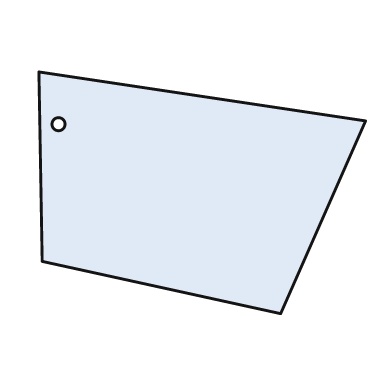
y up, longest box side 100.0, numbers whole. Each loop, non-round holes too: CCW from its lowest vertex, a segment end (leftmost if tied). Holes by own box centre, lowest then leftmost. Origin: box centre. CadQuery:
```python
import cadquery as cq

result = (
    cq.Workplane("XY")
    .moveTo(24.0, -37.0)
    .lineTo(50.0, 22.0)
    .lineTo(-50.0, 37.0)
    .lineTo(-49.0, -21.0)
    .close()
    .moveTo(-44.0, 21.0)
    .circle(2.0)
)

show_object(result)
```